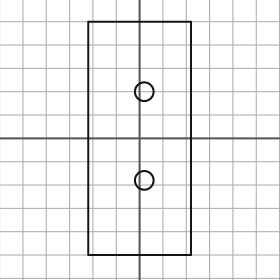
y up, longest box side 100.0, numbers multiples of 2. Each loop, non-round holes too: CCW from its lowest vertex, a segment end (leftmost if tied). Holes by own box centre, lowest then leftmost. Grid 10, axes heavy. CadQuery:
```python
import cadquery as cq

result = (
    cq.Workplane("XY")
    .moveTo(-22.0, -50.0)
    .lineTo(22.0, -50.0)
    .lineTo(22.0, 50.0)
    .lineTo(-22.0, 50.0)
    .close()
    .moveTo(2.0, -18.0)
    .circle(4.0)
    .moveTo(2.0, 20.0)
    .circle(4.0)
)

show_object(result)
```